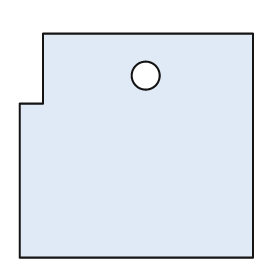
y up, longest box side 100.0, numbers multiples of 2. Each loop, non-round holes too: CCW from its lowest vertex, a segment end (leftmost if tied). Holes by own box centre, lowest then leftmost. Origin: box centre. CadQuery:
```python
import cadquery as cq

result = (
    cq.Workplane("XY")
    .moveTo(-50.0, -48.0)
    .lineTo(50.0, -48.0)
    .lineTo(50.0, 48.0)
    .lineTo(-40.0, 48.0)
    .lineTo(-40.0, 18.0)
    .lineTo(-50.0, 18.0)
    .close()
    .moveTo(4.0, 30.0)
    .circle(6.0)
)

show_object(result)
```